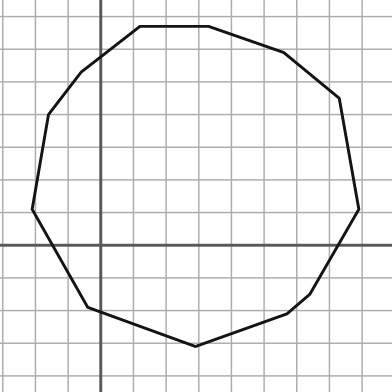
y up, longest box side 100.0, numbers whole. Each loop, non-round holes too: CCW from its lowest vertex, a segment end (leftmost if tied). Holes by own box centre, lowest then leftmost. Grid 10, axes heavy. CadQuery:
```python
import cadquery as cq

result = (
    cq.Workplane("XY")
    .moveTo(29.0, -31.0)
    .lineTo(57.0, -21.0)
    .lineTo(64.0, -15.0)
    .lineTo(79.0, 11.0)
    .lineTo(73.0, 45.0)
    .lineTo(56.0, 59.0)
    .lineTo(33.0, 67.0)
    .lineTo(12.0, 67.0)
    .lineTo(-6.0, 53.0)
    .lineTo(-16.0, 40.0)
    .lineTo(-21.0, 11.0)
    .lineTo(-4.0, -19.0)
    .close()
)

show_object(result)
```